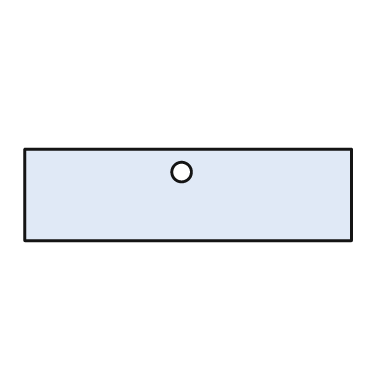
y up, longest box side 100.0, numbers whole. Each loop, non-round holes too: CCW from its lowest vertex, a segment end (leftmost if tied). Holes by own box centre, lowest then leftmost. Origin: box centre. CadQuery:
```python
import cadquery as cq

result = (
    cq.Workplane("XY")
    .moveTo(-50.0, -14.0)
    .lineTo(50.0, -14.0)
    .lineTo(50.0, 14.0)
    .lineTo(-50.0, 14.0)
    .close()
    .moveTo(-2.0, 7.0)
    .circle(3.0)
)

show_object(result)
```